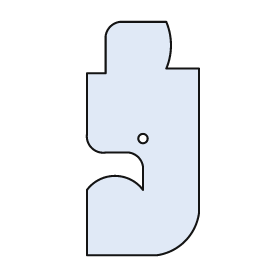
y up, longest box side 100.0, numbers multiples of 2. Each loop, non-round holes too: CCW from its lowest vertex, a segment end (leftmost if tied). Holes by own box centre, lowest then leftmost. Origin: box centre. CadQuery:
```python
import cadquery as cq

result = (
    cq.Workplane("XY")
    .moveTo(-24.0, -50.0)
    .lineTo(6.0, -50.0)
    .threePointArc((18.0, -44.0), (24.0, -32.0))
    .lineTo(24.0, 30.0)
    .lineTo(10.0, 30.0)
    .threePointArc((12.0, 40.0), (10.0, 50.0))
    .lineTo(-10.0, 50.0)
    .threePointArc((-14.0, 48.0), (-16.0, 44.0))
    .lineTo(-16.0, 28.0)
    .lineTo(-24.0, 28.0)
    .lineTo(-24.0, 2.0)
    .threePointArc((-22.0, -4.0), (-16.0, -6.0))
    .lineTo(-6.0, -6.0)
    .threePointArc((-2.0, -8.0), (0.0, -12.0))
    .lineTo(0.0, -22.0)
    .threePointArc((-12.0, -16.0), (-24.0, -22.0))
    .close()
    .moveTo(0.0, 0.0)
    .circle(2.0)
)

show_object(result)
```